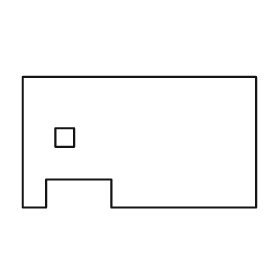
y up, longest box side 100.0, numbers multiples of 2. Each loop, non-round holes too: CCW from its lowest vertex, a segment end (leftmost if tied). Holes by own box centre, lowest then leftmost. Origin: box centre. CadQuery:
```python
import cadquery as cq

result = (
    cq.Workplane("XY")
    .moveTo(-50.0, -28.0)
    .lineTo(-40.0, -28.0)
    .lineTo(-40.0, -16.0)
    .lineTo(-12.0, -16.0)
    .lineTo(-12.0, -28.0)
    .lineTo(50.0, -28.0)
    .lineTo(50.0, 28.0)
    .lineTo(-50.0, 28.0)
    .close()
    .moveTo(-36.0, -2.0)
    .lineTo(-28.0, -2.0)
    .lineTo(-28.0, 6.0)
    .lineTo(-36.0, 6.0)
    .close()
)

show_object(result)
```